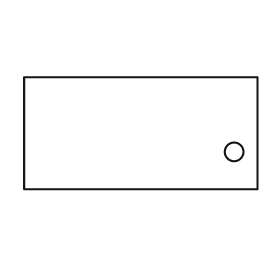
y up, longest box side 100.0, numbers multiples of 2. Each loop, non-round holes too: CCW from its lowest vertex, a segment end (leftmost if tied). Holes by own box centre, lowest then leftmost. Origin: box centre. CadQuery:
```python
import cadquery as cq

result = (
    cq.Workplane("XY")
    .moveTo(-50.0, -24.0)
    .lineTo(50.0, -24.0)
    .lineTo(50.0, 24.0)
    .lineTo(-50.0, 24.0)
    .close()
    .moveTo(40.0, -8.0)
    .circle(4.0)
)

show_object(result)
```